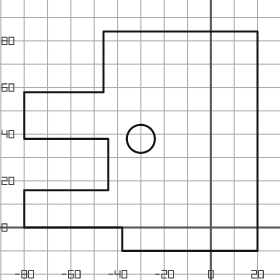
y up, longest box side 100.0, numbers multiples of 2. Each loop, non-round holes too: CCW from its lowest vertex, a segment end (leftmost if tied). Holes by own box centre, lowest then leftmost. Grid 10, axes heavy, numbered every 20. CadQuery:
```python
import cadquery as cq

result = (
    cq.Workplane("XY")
    .moveTo(-38.0, -10.0)
    .lineTo(20.0, -10.0)
    .lineTo(20.0, 84.0)
    .lineTo(-46.0, 84.0)
    .lineTo(-46.0, 58.0)
    .lineTo(-80.0, 58.0)
    .lineTo(-80.0, 38.0)
    .lineTo(-44.0, 38.0)
    .lineTo(-44.0, 16.0)
    .lineTo(-80.0, 16.0)
    .lineTo(-80.0, 0.0)
    .lineTo(-38.0, 0.0)
    .close()
    .moveTo(-30.0, 38.0)
    .circle(6.0)
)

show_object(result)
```